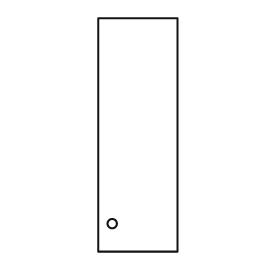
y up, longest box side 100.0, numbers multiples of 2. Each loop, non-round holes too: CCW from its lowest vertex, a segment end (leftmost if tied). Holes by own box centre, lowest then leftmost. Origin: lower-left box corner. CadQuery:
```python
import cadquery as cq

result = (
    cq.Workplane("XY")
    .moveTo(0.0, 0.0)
    .lineTo(34.0, 0.0)
    .lineTo(34.0, 100.0)
    .lineTo(0.0, 100.0)
    .close()
    .moveTo(6.0, 12.0)
    .circle(2.0)
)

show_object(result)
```